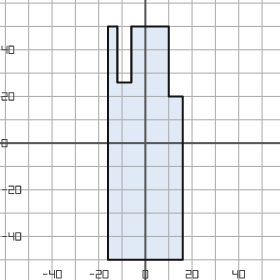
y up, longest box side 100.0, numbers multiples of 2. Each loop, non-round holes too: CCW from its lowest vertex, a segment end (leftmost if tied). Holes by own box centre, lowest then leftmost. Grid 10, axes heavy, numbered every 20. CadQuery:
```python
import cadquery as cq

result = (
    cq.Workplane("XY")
    .moveTo(-16.0, -50.0)
    .lineTo(16.0, -50.0)
    .lineTo(16.0, 20.0)
    .lineTo(10.0, 20.0)
    .lineTo(10.0, 50.0)
    .lineTo(-6.0, 50.0)
    .lineTo(-6.0, 26.0)
    .lineTo(-12.0, 26.0)
    .lineTo(-12.0, 50.0)
    .lineTo(-16.0, 50.0)
    .close()
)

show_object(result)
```